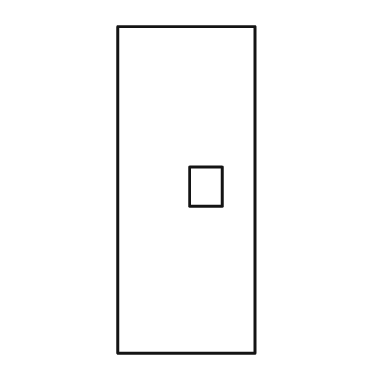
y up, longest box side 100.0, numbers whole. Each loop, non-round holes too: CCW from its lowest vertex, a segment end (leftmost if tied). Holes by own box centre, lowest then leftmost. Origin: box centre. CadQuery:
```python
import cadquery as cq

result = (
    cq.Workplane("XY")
    .moveTo(-21.0, -50.0)
    .lineTo(21.0, -50.0)
    .lineTo(21.0, 50.0)
    .lineTo(-21.0, 50.0)
    .close()
    .moveTo(1.0, -5.0)
    .lineTo(11.0, -5.0)
    .lineTo(11.0, 7.0)
    .lineTo(1.0, 7.0)
    .close()
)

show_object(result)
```